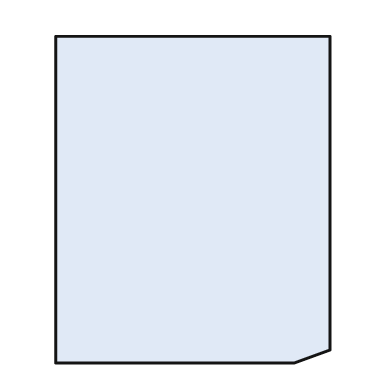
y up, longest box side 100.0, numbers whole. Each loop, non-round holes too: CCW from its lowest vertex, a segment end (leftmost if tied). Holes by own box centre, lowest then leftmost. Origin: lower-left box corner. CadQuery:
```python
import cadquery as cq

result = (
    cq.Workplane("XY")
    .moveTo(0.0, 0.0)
    .lineTo(73.0, 0.0)
    .lineTo(84.0, 4.0)
    .lineTo(84.0, 100.0)
    .lineTo(0.0, 100.0)
    .close()
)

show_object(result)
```